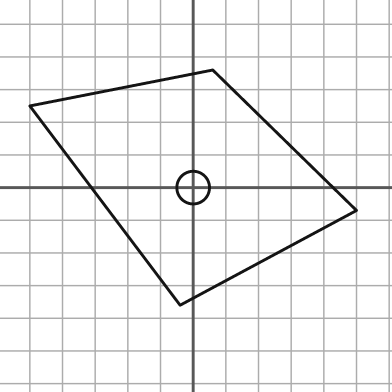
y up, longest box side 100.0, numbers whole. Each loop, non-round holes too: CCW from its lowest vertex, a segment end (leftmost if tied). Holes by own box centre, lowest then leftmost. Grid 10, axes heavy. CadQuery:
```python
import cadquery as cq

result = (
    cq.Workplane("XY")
    .moveTo(-4.0, -36.0)
    .lineTo(50.0, -7.0)
    .lineTo(6.0, 36.0)
    .lineTo(-50.0, 25.0)
    .close()
    .moveTo(0.0, 0.0)
    .circle(5.0)
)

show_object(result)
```